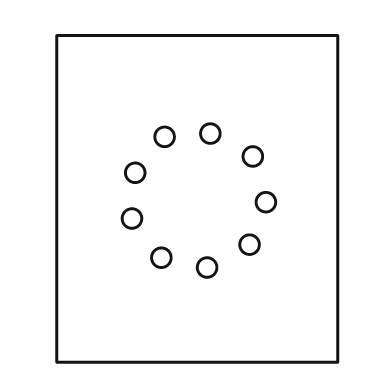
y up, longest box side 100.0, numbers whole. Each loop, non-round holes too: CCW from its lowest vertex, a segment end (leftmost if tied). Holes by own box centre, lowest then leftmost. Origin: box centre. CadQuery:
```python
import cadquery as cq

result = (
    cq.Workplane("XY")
    .moveTo(-43.0, -50.0)
    .lineTo(43.0, -50.0)
    .lineTo(43.0, 50.0)
    .lineTo(-43.0, 50.0)
    .close()
    .moveTo(3.0, -21.0)
    .circle(3.0)
    .moveTo(-11.0, -18.0)
    .circle(3.0)
    .moveTo(16.0, -14.0)
    .circle(3.0)
    .moveTo(-20.0, -6.0)
    .circle(3.0)
    .moveTo(21.0, -1.0)
    .circle(3.0)
    .moveTo(-19.0, 8.0)
    .circle(3.0)
    .moveTo(17.0, 13.0)
    .circle(3.0)
    .moveTo(-10.0, 19.0)
    .circle(3.0)
    .moveTo(4.0, 20.0)
    .circle(3.0)
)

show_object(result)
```